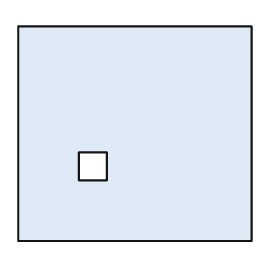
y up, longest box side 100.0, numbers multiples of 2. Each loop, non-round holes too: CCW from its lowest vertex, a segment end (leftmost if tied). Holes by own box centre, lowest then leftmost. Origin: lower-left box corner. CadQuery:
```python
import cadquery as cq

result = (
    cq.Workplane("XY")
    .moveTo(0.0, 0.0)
    .lineTo(100.0, 0.0)
    .lineTo(100.0, 92.0)
    .lineTo(0.0, 92.0)
    .close()
    .moveTo(26.0, 26.0)
    .lineTo(38.0, 26.0)
    .lineTo(38.0, 38.0)
    .lineTo(26.0, 38.0)
    .close()
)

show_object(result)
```